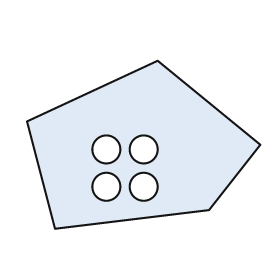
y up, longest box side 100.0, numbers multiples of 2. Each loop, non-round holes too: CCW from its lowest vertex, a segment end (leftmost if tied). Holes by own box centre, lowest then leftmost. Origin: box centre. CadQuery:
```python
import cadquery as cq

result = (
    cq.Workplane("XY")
    .moveTo(-38.0, -36.0)
    .lineTo(28.0, -28.0)
    .lineTo(50.0, 0.0)
    .lineTo(6.0, 36.0)
    .lineTo(-50.0, 10.0)
    .close()
    .moveTo(-16.0, -18.0)
    .circle(6.0)
    .moveTo(0.0, -18.0)
    .circle(6.0)
    .moveTo(-16.0, -2.0)
    .circle(6.0)
    .moveTo(0.0, -2.0)
    .circle(6.0)
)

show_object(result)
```